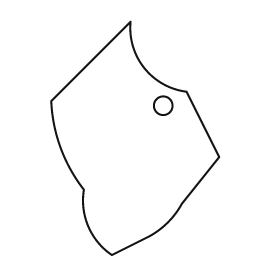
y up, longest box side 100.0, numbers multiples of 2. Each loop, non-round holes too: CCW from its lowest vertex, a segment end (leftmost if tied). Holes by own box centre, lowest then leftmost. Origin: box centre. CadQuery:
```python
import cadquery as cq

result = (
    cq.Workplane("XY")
    .moveTo(-10.0, -50.0)
    .lineTo(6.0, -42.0)
    .threePointArc((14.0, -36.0), (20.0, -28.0))
    .lineTo(36.0, -8.0)
    .lineTo(22.0, 20.0)
    .threePointArc((4.0, 30.0), (-2.0, 50.0))
    .lineTo(-36.0, 16.0)
    .threePointArc((-32.0, -4.0), (-22.0, -22.0))
    .threePointArc((-20.0, -38.0), (-10.0, -50.0))
    .close()
    .moveTo(12.0, 14.0)
    .circle(4.0)
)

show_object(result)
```